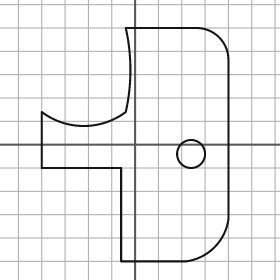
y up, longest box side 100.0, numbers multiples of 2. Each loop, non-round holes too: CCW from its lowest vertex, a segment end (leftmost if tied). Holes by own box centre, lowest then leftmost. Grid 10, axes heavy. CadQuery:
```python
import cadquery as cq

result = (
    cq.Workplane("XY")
    .moveTo(-6.0, -50.0)
    .lineTo(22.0, -50.0)
    .threePointArc((34.0, -44.0), (40.0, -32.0))
    .lineTo(40.0, 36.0)
    .threePointArc((36.0, 46.0), (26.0, 50.0))
    .lineTo(-4.0, 50.0)
    .threePointArc((-2.0, 32.0), (-4.0, 14.0))
    .threePointArc((-22.0, 8.0), (-40.0, 14.0))
    .lineTo(-40.0, -10.0)
    .lineTo(-6.0, -10.0)
    .close()
    .moveTo(24.0, -4.0)
    .circle(6.0)
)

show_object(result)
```